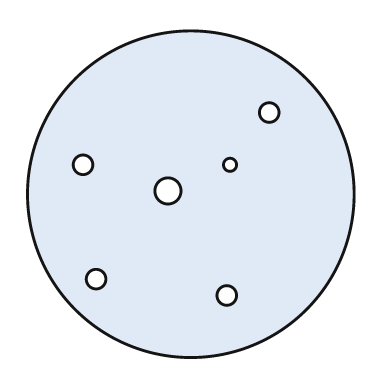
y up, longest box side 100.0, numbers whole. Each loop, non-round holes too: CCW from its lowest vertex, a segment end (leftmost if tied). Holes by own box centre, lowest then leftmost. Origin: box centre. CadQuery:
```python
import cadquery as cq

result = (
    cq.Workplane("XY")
    .moveTo(0.0, 0.0)
    .circle(50.0)
    .moveTo(11.0, -31.0)
    .circle(3.0)
    .moveTo(-29.0, -26.0)
    .circle(3.0)
    .moveTo(-7.0, 1.0)
    .circle(4.0)
    .moveTo(-33.0, 9.0)
    .circle(3.0)
    .moveTo(12.0, 9.0)
    .circle(2.0)
    .moveTo(24.0, 25.0)
    .circle(3.0)
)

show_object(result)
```